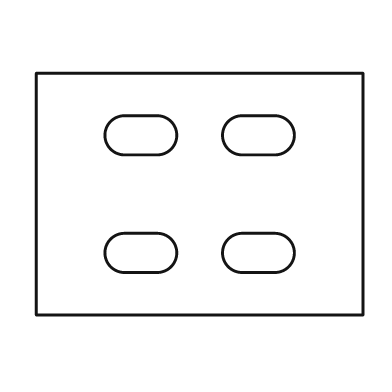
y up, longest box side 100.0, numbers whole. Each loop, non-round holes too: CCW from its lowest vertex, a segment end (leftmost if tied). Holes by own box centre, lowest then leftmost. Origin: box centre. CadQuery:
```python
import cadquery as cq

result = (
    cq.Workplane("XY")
    .moveTo(-50.0, -37.0)
    .lineTo(50.0, -37.0)
    .lineTo(50.0, 37.0)
    .lineTo(-50.0, 37.0)
    .close()
    .moveTo(-23.0, -24.0)
    .lineTo(-13.0, -24.0)
    .threePointArc((-7.0, -18.0), (-13.0, -12.0))
    .lineTo(-23.0, -12.0)
    .threePointArc((-29.0, -18.0), (-23.0, -24.0))
    .close()
    .moveTo(13.0, -24.0)
    .lineTo(23.0, -24.0)
    .threePointArc((29.0, -18.0), (23.0, -12.0))
    .lineTo(13.0, -12.0)
    .threePointArc((7.0, -18.0), (13.0, -24.0))
    .close()
    .moveTo(-23.0, 12.0)
    .lineTo(-13.0, 12.0)
    .threePointArc((-7.0, 18.0), (-13.0, 24.0))
    .lineTo(-23.0, 24.0)
    .threePointArc((-29.0, 18.0), (-23.0, 12.0))
    .close()
    .moveTo(13.0, 12.0)
    .lineTo(23.0, 12.0)
    .threePointArc((29.0, 18.0), (23.0, 24.0))
    .lineTo(13.0, 24.0)
    .threePointArc((7.0, 18.0), (13.0, 12.0))
    .close()
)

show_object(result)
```